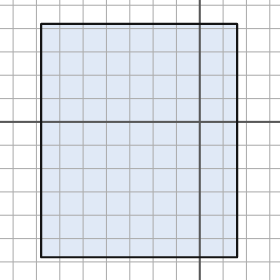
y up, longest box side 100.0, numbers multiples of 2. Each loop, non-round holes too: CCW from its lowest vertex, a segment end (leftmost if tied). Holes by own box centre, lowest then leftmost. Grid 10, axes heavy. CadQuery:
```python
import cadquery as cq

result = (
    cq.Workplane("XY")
    .moveTo(-68.0, -58.0)
    .lineTo(16.0, -58.0)
    .lineTo(16.0, 42.0)
    .lineTo(-68.0, 42.0)
    .close()
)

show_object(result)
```